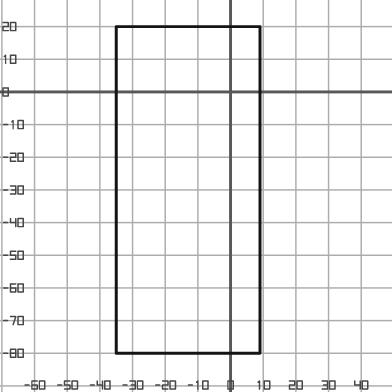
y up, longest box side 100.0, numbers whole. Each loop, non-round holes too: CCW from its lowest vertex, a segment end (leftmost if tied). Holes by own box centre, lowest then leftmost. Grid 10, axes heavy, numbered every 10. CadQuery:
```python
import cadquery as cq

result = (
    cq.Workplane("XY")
    .moveTo(-35.0, -80.0)
    .lineTo(9.0, -80.0)
    .lineTo(9.0, 20.0)
    .lineTo(-35.0, 20.0)
    .close()
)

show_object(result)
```